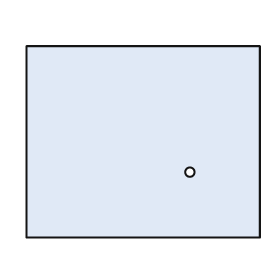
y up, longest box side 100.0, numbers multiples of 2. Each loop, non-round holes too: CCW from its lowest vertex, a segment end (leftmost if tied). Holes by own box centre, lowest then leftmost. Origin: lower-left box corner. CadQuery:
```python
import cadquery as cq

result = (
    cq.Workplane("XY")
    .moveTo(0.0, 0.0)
    .lineTo(100.0, 0.0)
    .lineTo(100.0, 82.0)
    .lineTo(0.0, 82.0)
    .close()
    .moveTo(70.0, 28.0)
    .circle(2.0)
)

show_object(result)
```